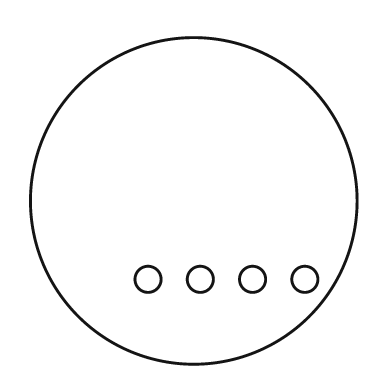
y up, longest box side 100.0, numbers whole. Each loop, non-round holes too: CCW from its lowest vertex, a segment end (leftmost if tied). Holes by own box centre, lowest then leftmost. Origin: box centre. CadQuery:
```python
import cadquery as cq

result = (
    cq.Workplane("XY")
    .moveTo(0.0, 0.0)
    .circle(50.0)
    .moveTo(-14.0, -24.0)
    .circle(4.0)
    .moveTo(2.0, -24.0)
    .circle(4.0)
    .moveTo(18.0, -24.0)
    .circle(4.0)
    .moveTo(34.0, -24.0)
    .circle(4.0)
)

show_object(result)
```